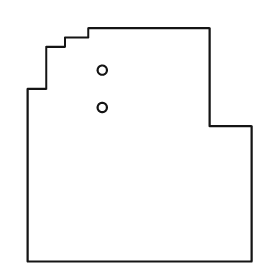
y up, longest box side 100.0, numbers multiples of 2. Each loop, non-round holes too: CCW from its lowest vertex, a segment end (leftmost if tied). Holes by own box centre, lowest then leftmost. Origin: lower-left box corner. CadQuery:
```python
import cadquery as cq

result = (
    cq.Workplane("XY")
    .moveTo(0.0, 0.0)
    .lineTo(96.0, 0.0)
    .lineTo(96.0, 58.0)
    .lineTo(78.0, 58.0)
    .lineTo(78.0, 100.0)
    .lineTo(26.0, 100.0)
    .lineTo(26.0, 96.0)
    .lineTo(16.0, 96.0)
    .lineTo(16.0, 92.0)
    .lineTo(8.0, 92.0)
    .lineTo(8.0, 74.0)
    .lineTo(0.0, 74.0)
    .close()
    .moveTo(32.0, 66.0)
    .circle(2.0)
    .moveTo(32.0, 82.0)
    .circle(2.0)
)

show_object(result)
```